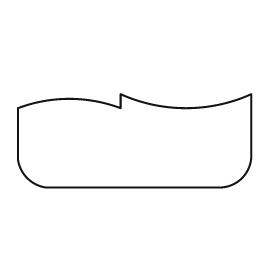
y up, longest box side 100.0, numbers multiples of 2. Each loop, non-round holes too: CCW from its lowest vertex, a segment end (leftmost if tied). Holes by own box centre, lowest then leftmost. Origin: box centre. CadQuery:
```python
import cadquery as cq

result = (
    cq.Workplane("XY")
    .moveTo(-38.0, -20.0)
    .lineTo(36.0, -20.0)
    .threePointArc((46.0, -16.0), (50.0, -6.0))
    .lineTo(50.0, 20.0)
    .threePointArc((22.0, 14.0), (-6.0, 20.0))
    .lineTo(-6.0, 14.0)
    .threePointArc((-28.0, 18.0), (-50.0, 14.0))
    .lineTo(-50.0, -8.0)
    .threePointArc((-46.0, -16.0), (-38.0, -20.0))
    .close()
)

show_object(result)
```